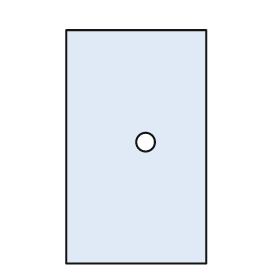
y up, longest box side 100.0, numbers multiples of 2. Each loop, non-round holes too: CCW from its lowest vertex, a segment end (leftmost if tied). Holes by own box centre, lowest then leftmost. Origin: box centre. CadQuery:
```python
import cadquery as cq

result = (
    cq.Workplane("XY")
    .moveTo(-30.0, -50.0)
    .lineTo(30.0, -50.0)
    .lineTo(30.0, 50.0)
    .lineTo(-30.0, 50.0)
    .close()
    .moveTo(4.0, 2.0)
    .circle(4.0)
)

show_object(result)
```